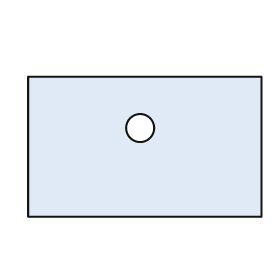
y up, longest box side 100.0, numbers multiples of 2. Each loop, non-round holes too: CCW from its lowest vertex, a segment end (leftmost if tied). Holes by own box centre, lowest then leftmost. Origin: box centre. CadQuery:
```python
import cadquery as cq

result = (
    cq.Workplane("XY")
    .moveTo(-50.0, -30.0)
    .lineTo(50.0, -30.0)
    .lineTo(50.0, 30.0)
    .lineTo(-50.0, 30.0)
    .close()
    .moveTo(-2.0, 8.0)
    .circle(6.0)
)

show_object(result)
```